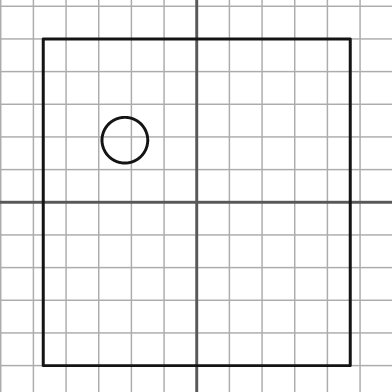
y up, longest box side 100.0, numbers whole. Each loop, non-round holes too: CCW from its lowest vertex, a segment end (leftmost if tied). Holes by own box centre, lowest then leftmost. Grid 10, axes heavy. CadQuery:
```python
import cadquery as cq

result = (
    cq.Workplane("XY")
    .moveTo(-47.0, -50.0)
    .lineTo(47.0, -50.0)
    .lineTo(47.0, 50.0)
    .lineTo(-47.0, 50.0)
    .close()
    .moveTo(-22.0, 19.0)
    .circle(7.0)
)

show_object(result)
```